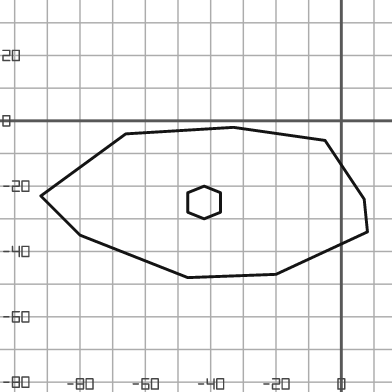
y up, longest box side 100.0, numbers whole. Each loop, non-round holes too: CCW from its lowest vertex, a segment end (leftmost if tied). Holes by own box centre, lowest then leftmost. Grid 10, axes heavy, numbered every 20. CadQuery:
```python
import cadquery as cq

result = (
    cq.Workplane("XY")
    .moveTo(-47.0, -48.0)
    .lineTo(-20.0, -47.0)
    .lineTo(8.0, -34.0)
    .lineTo(7.0, -24.0)
    .lineTo(-5.0, -6.0)
    .lineTo(-33.0, -2.0)
    .lineTo(-66.0, -4.0)
    .lineTo(-92.0, -23.0)
    .lineTo(-80.0, -35.0)
    .close()
    .moveTo(-42.0, -30.0)
    .lineTo(-37.0, -28.0)
    .lineTo(-37.0, -22.0)
    .lineTo(-42.0, -20.0)
    .lineTo(-47.0, -22.0)
    .lineTo(-47.0, -28.0)
    .close()
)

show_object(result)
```